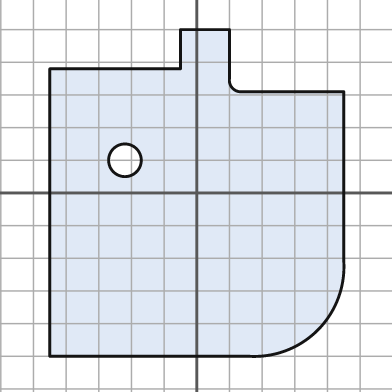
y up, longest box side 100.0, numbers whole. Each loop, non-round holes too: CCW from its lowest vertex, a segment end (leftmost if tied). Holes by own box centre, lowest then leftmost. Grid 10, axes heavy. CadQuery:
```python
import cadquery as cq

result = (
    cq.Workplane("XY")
    .moveTo(-45.0, -50.0)
    .lineTo(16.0, -50.0)
    .threePointArc((37.0, -42.0), (45.0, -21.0))
    .lineTo(45.0, 31.0)
    .lineTo(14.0, 31.0)
    .threePointArc((11.0, 32.0), (10.0, 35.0))
    .lineTo(10.0, 50.0)
    .lineTo(-5.0, 50.0)
    .lineTo(-5.0, 38.0)
    .lineTo(-45.0, 38.0)
    .close()
    .moveTo(-22.0, 10.0)
    .circle(5.0)
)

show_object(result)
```